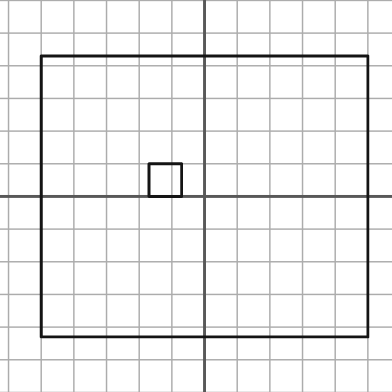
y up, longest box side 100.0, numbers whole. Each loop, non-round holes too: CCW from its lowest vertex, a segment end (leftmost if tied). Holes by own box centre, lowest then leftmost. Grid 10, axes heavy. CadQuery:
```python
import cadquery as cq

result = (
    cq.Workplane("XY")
    .moveTo(-50.0, -43.0)
    .lineTo(50.0, -43.0)
    .lineTo(50.0, 43.0)
    .lineTo(-50.0, 43.0)
    .close()
    .moveTo(-17.0, 0.0)
    .lineTo(-7.0, 0.0)
    .lineTo(-7.0, 10.0)
    .lineTo(-17.0, 10.0)
    .close()
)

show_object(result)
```